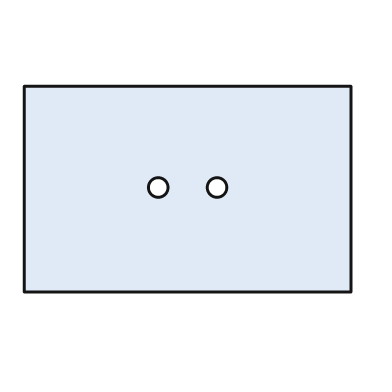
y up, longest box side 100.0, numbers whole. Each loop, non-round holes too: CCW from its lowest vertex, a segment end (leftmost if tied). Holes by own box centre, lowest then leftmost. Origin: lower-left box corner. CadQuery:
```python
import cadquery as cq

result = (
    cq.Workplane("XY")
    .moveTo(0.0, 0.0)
    .lineTo(100.0, 0.0)
    .lineTo(100.0, 63.0)
    .lineTo(0.0, 63.0)
    .close()
    .moveTo(41.0, 32.0)
    .circle(3.0)
    .moveTo(59.0, 32.0)
    .circle(3.0)
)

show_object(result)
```